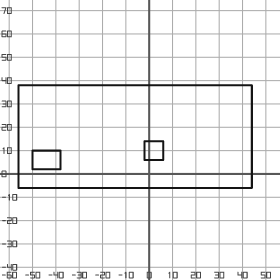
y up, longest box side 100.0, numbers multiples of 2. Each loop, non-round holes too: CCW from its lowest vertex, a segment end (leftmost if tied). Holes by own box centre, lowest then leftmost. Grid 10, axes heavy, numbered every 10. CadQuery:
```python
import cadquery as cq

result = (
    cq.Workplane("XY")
    .moveTo(-56.0, -6.0)
    .lineTo(44.0, -6.0)
    .lineTo(44.0, 38.0)
    .lineTo(-56.0, 38.0)
    .close()
    .moveTo(-50.0, 2.0)
    .lineTo(-38.0, 2.0)
    .lineTo(-38.0, 10.0)
    .lineTo(-50.0, 10.0)
    .close()
    .moveTo(-2.0, 6.0)
    .lineTo(6.0, 6.0)
    .lineTo(6.0, 14.0)
    .lineTo(-2.0, 14.0)
    .close()
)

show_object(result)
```